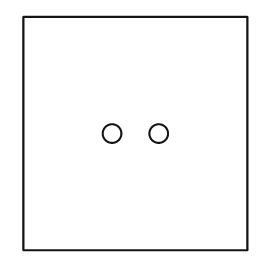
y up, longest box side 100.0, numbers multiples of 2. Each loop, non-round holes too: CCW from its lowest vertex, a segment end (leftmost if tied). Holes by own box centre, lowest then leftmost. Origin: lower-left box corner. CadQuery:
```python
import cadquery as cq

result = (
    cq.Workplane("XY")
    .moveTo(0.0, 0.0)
    .lineTo(96.0, 0.0)
    .lineTo(96.0, 100.0)
    .lineTo(0.0, 100.0)
    .close()
    .moveTo(38.0, 50.0)
    .circle(4.0)
    .moveTo(58.0, 50.0)
    .circle(4.0)
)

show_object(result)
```